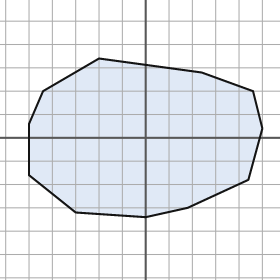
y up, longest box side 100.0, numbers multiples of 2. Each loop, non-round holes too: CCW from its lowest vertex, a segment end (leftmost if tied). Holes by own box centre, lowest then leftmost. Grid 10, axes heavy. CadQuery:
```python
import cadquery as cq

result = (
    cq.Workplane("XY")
    .moveTo(0.0, -34.0)
    .lineTo(18.0, -30.0)
    .lineTo(44.0, -18.0)
    .lineTo(50.0, 4.0)
    .lineTo(46.0, 20.0)
    .lineTo(24.0, 28.0)
    .lineTo(-20.0, 34.0)
    .lineTo(-44.0, 20.0)
    .lineTo(-50.0, 6.0)
    .lineTo(-50.0, -16.0)
    .lineTo(-30.0, -32.0)
    .close()
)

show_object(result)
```